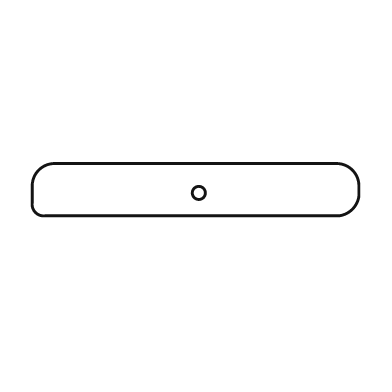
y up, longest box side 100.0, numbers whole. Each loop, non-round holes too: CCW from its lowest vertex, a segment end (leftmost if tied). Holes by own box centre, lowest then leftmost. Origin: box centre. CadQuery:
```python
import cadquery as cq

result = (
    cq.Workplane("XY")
    .moveTo(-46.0, -8.0)
    .lineTo(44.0, -8.0)
    .threePointArc((48.0, -6.0), (50.0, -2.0))
    .lineTo(50.0, 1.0)
    .threePointArc((48.0, 6.0), (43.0, 8.0))
    .lineTo(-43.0, 8.0)
    .threePointArc((-48.0, 6.0), (-50.0, 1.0))
    .lineTo(-50.0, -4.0)
    .threePointArc((-49.0, -7.0), (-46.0, -8.0))
    .close()
    .moveTo(1.0, -1.0)
    .circle(2.0)
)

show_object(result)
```